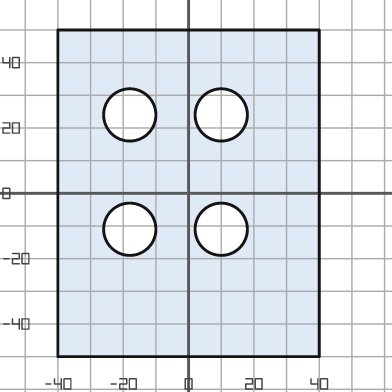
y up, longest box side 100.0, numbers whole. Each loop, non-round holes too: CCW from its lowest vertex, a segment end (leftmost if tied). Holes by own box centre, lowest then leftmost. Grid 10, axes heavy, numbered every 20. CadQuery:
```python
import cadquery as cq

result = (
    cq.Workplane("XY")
    .moveTo(-40.0, -50.0)
    .lineTo(40.0, -50.0)
    .lineTo(40.0, 50.0)
    .lineTo(-40.0, 50.0)
    .close()
    .moveTo(-18.0, -11.0)
    .circle(8.0)
    .moveTo(10.0, -11.0)
    .circle(8.0)
    .moveTo(-18.0, 24.0)
    .circle(8.0)
    .moveTo(10.0, 24.0)
    .circle(8.0)
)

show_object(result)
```